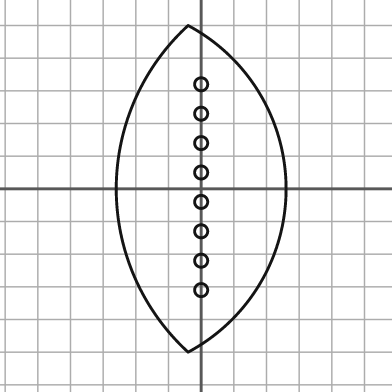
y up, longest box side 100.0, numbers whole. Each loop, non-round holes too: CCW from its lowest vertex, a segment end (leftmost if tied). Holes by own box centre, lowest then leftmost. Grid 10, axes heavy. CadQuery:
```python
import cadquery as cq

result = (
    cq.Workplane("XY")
    .moveTo(-4.0, -50.0)
    .threePointArc((26.0, 0.0), (-4.0, 50.0))
    .threePointArc((-26.0, 0.0), (-4.0, -50.0))
    .close()
    .moveTo(0.0, -31.0)
    .circle(2.0)
    .moveTo(0.0, -22.0)
    .circle(2.0)
    .moveTo(0.0, -13.0)
    .circle(2.0)
    .moveTo(0.0, -4.0)
    .circle(2.0)
    .moveTo(0.0, 5.0)
    .circle(2.0)
    .moveTo(0.0, 14.0)
    .circle(2.0)
    .moveTo(0.0, 23.0)
    .circle(2.0)
    .moveTo(0.0, 32.0)
    .circle(2.0)
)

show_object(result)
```